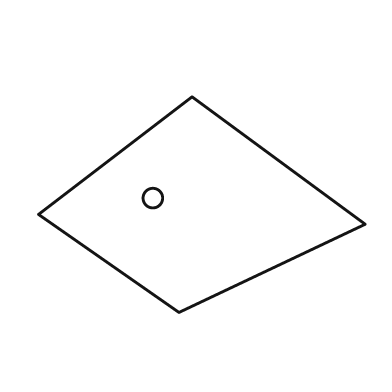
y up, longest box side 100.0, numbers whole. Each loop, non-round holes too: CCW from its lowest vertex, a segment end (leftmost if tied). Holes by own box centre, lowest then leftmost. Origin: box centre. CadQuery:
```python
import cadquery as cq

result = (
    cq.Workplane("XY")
    .moveTo(-7.0, -33.0)
    .lineTo(50.0, -6.0)
    .lineTo(-3.0, 33.0)
    .lineTo(-50.0, -3.0)
    .close()
    .moveTo(-15.0, 2.0)
    .circle(3.0)
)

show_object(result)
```